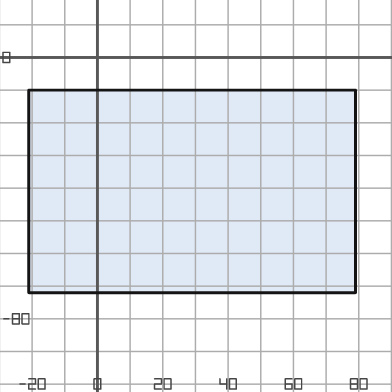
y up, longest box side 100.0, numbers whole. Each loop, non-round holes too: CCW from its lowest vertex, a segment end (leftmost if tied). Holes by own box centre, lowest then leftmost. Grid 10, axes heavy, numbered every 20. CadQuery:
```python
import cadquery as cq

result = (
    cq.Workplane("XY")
    .moveTo(-21.0, -72.0)
    .lineTo(79.0, -72.0)
    .lineTo(79.0, -10.0)
    .lineTo(-21.0, -10.0)
    .close()
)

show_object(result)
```